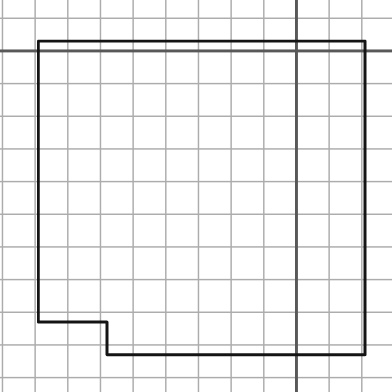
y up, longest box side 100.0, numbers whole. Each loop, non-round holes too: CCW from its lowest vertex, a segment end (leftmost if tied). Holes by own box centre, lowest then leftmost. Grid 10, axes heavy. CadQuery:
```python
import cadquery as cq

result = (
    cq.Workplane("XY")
    .moveTo(-58.0, -93.0)
    .lineTo(21.0, -93.0)
    .lineTo(21.0, 3.0)
    .lineTo(-79.0, 3.0)
    .lineTo(-79.0, -83.0)
    .lineTo(-58.0, -83.0)
    .close()
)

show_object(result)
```